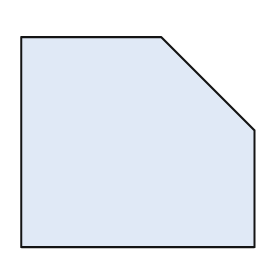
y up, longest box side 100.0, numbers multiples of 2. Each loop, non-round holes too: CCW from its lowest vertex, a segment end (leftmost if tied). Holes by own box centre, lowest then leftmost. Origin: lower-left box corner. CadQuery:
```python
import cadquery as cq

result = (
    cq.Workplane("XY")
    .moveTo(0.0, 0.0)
    .lineTo(100.0, 0.0)
    .lineTo(100.0, 50.0)
    .lineTo(60.0, 90.0)
    .lineTo(0.0, 90.0)
    .close()
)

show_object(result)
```